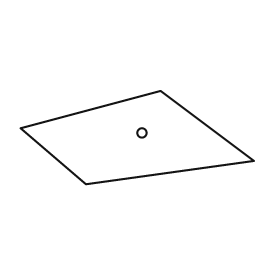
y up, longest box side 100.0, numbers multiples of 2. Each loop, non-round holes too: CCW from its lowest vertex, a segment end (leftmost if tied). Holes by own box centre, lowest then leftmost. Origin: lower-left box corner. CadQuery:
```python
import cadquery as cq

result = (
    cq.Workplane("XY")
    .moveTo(28.0, 0.0)
    .lineTo(100.0, 10.0)
    .lineTo(60.0, 40.0)
    .lineTo(0.0, 24.0)
    .close()
    .moveTo(52.0, 22.0)
    .circle(2.0)
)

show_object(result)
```